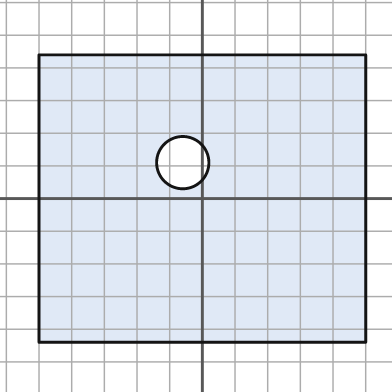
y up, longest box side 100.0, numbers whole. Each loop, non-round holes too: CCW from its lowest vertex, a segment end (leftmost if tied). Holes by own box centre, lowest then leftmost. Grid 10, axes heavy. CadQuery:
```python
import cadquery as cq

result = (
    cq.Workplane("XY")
    .moveTo(-50.0, -44.0)
    .lineTo(50.0, -44.0)
    .lineTo(50.0, 44.0)
    .lineTo(-50.0, 44.0)
    .close()
    .moveTo(-6.0, 11.0)
    .circle(8.0)
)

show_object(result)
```